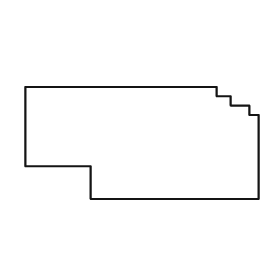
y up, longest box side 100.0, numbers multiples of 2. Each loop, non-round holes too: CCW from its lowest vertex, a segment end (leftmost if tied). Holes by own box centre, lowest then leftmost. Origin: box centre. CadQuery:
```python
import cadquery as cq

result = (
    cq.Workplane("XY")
    .moveTo(-22.0, -24.0)
    .lineTo(50.0, -24.0)
    .lineTo(50.0, 12.0)
    .lineTo(46.0, 12.0)
    .lineTo(46.0, 16.0)
    .lineTo(38.0, 16.0)
    .lineTo(38.0, 20.0)
    .lineTo(32.0, 20.0)
    .lineTo(32.0, 24.0)
    .lineTo(-50.0, 24.0)
    .lineTo(-50.0, -10.0)
    .lineTo(-22.0, -10.0)
    .close()
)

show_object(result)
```